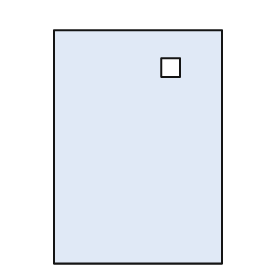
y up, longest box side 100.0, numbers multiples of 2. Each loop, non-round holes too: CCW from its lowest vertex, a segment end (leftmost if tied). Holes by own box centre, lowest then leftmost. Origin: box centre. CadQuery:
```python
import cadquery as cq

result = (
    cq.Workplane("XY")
    .moveTo(-36.0, -50.0)
    .lineTo(36.0, -50.0)
    .lineTo(36.0, 50.0)
    .lineTo(-36.0, 50.0)
    .close()
    .moveTo(10.0, 30.0)
    .lineTo(18.0, 30.0)
    .lineTo(18.0, 38.0)
    .lineTo(10.0, 38.0)
    .close()
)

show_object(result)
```